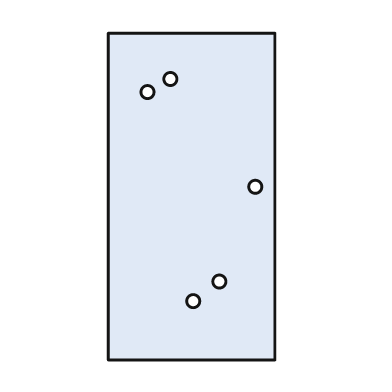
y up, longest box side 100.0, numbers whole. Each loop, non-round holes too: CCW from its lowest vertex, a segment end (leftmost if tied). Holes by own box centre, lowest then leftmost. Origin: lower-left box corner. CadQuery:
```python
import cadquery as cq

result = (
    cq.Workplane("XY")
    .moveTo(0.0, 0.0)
    .lineTo(51.0, 0.0)
    .lineTo(51.0, 100.0)
    .lineTo(0.0, 100.0)
    .close()
    .moveTo(26.0, 18.0)
    .circle(2.0)
    .moveTo(34.0, 24.0)
    .circle(2.0)
    .moveTo(45.0, 53.0)
    .circle(2.0)
    .moveTo(12.0, 82.0)
    .circle(2.0)
    .moveTo(19.0, 86.0)
    .circle(2.0)
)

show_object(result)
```